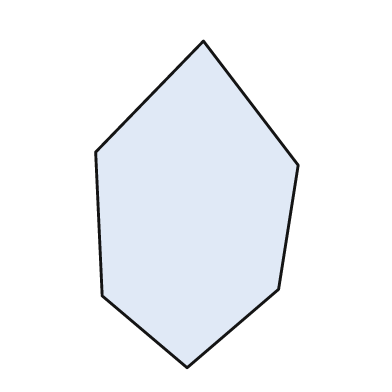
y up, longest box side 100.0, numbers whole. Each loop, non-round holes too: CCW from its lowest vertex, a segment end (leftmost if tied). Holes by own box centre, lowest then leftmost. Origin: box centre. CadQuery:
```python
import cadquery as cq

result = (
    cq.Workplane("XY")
    .moveTo(-3.0, -50.0)
    .lineTo(25.0, -26.0)
    .lineTo(31.0, 12.0)
    .lineTo(2.0, 50.0)
    .lineTo(-31.0, 16.0)
    .lineTo(-29.0, -28.0)
    .close()
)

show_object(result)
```